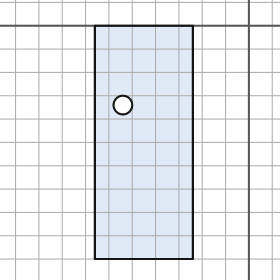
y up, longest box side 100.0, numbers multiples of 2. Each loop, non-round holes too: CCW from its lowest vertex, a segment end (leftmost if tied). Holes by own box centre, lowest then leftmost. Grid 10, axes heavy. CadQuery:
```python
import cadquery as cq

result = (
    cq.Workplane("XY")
    .moveTo(-66.0, -100.0)
    .lineTo(-24.0, -100.0)
    .lineTo(-24.0, 0.0)
    .lineTo(-66.0, 0.0)
    .close()
    .moveTo(-54.0, -34.0)
    .circle(4.0)
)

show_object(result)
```